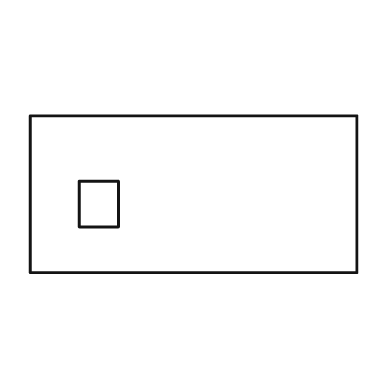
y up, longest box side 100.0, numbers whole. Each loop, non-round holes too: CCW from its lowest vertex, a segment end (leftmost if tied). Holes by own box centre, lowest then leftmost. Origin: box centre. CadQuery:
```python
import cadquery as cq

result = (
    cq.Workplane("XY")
    .moveTo(-50.0, -24.0)
    .lineTo(50.0, -24.0)
    .lineTo(50.0, 24.0)
    .lineTo(-50.0, 24.0)
    .close()
    .moveTo(-35.0, -10.0)
    .lineTo(-23.0, -10.0)
    .lineTo(-23.0, 4.0)
    .lineTo(-35.0, 4.0)
    .close()
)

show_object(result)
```